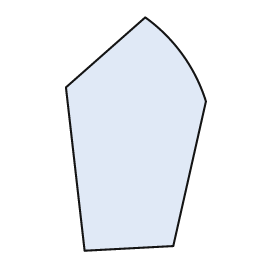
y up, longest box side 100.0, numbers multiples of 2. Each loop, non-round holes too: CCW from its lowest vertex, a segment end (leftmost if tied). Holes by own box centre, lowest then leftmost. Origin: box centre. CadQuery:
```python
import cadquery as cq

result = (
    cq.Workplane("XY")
    .moveTo(-22.0, -50.0)
    .lineTo(16.0, -48.0)
    .lineTo(30.0, 14.0)
    .threePointArc((20.0, 34.0), (4.0, 50.0))
    .lineTo(-30.0, 20.0)
    .close()
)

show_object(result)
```